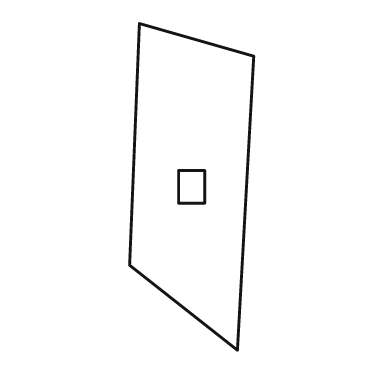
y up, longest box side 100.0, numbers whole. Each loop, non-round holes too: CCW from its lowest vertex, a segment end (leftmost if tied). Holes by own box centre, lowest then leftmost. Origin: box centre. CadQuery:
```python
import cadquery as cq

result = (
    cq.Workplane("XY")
    .moveTo(14.0, -50.0)
    .lineTo(19.0, 40.0)
    .lineTo(-16.0, 50.0)
    .lineTo(-19.0, -24.0)
    .close()
    .moveTo(-4.0, -5.0)
    .lineTo(4.0, -5.0)
    .lineTo(4.0, 5.0)
    .lineTo(-4.0, 5.0)
    .close()
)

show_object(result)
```